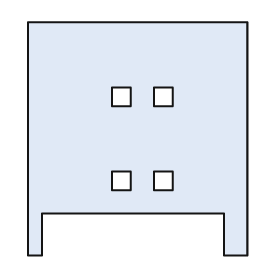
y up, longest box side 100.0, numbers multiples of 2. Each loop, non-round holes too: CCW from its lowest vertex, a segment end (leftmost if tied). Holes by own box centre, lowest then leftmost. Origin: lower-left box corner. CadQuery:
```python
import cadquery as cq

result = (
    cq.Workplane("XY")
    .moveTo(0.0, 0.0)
    .lineTo(6.0, 0.0)
    .lineTo(6.0, 18.0)
    .lineTo(84.0, 18.0)
    .lineTo(84.0, 0.0)
    .lineTo(94.0, 0.0)
    .lineTo(94.0, 100.0)
    .lineTo(0.0, 100.0)
    .close()
    .moveTo(36.0, 28.0)
    .lineTo(44.0, 28.0)
    .lineTo(44.0, 36.0)
    .lineTo(36.0, 36.0)
    .close()
    .moveTo(54.0, 28.0)
    .lineTo(62.0, 28.0)
    .lineTo(62.0, 36.0)
    .lineTo(54.0, 36.0)
    .close()
    .moveTo(36.0, 64.0)
    .lineTo(44.0, 64.0)
    .lineTo(44.0, 72.0)
    .lineTo(36.0, 72.0)
    .close()
    .moveTo(54.0, 64.0)
    .lineTo(62.0, 64.0)
    .lineTo(62.0, 72.0)
    .lineTo(54.0, 72.0)
    .close()
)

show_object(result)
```